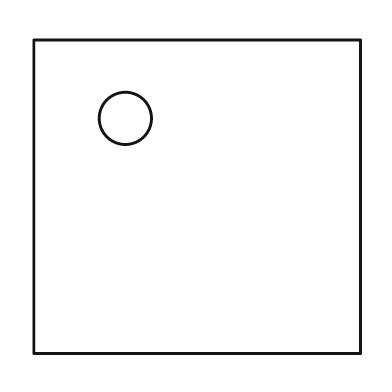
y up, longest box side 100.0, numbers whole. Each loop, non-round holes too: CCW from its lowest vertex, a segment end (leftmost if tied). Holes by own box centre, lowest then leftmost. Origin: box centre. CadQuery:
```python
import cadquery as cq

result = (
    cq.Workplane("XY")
    .moveTo(-50.0, -48.0)
    .lineTo(50.0, -48.0)
    .lineTo(50.0, 48.0)
    .lineTo(-50.0, 48.0)
    .close()
    .moveTo(-22.0, 24.0)
    .circle(8.0)
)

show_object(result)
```